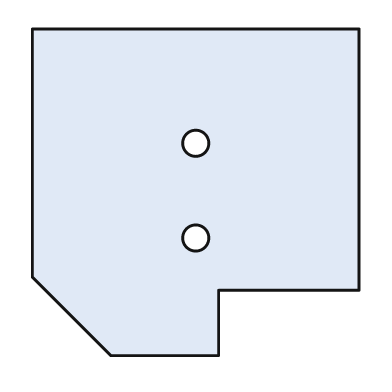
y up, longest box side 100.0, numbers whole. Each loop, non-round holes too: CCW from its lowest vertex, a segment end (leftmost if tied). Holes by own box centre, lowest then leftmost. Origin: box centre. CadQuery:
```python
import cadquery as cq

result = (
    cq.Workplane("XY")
    .moveTo(-26.0, -50.0)
    .lineTo(7.0, -50.0)
    .lineTo(7.0, -30.0)
    .lineTo(50.0, -30.0)
    .lineTo(50.0, 50.0)
    .lineTo(-50.0, 50.0)
    .lineTo(-50.0, -26.0)
    .close()
    .moveTo(0.0, -14.0)
    .circle(4.0)
    .moveTo(0.0, 15.0)
    .circle(4.0)
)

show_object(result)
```